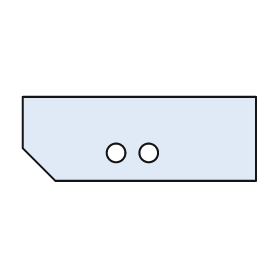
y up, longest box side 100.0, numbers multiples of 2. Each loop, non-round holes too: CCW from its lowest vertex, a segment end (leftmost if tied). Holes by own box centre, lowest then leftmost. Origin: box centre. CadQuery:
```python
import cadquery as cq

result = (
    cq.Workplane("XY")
    .moveTo(-36.0, -18.0)
    .lineTo(50.0, -18.0)
    .lineTo(50.0, 18.0)
    .lineTo(-50.0, 18.0)
    .lineTo(-50.0, -4.0)
    .close()
    .moveTo(-10.0, -6.0)
    .circle(4.0)
    .moveTo(4.0, -6.0)
    .circle(4.0)
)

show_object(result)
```